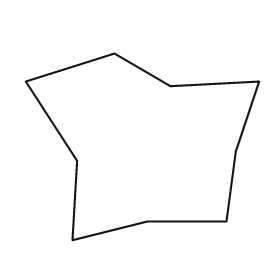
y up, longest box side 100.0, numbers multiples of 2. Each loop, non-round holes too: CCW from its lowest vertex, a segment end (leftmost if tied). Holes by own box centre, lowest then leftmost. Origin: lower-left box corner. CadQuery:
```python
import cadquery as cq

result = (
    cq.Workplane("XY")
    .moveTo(20.0, 0.0)
    .lineTo(52.0, 8.0)
    .lineTo(86.0, 8.0)
    .lineTo(90.0, 38.0)
    .lineTo(100.0, 68.0)
    .lineTo(62.0, 66.0)
    .lineTo(38.0, 80.0)
    .lineTo(0.0, 68.0)
    .lineTo(22.0, 34.0)
    .close()
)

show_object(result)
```